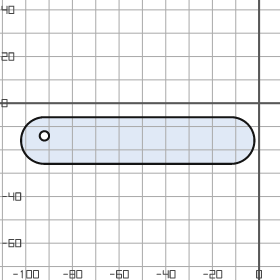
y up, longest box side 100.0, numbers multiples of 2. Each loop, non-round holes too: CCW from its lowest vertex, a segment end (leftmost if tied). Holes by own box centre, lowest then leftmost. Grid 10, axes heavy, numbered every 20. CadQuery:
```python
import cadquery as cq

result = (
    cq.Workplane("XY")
    .moveTo(-92.0, -26.0)
    .lineTo(-12.0, -26.0)
    .threePointArc((-2.0, -16.0), (-12.0, -6.0))
    .lineTo(-92.0, -6.0)
    .threePointArc((-102.0, -16.0), (-92.0, -26.0))
    .close()
    .moveTo(-92.0, -14.0)
    .circle(2.0)
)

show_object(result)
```